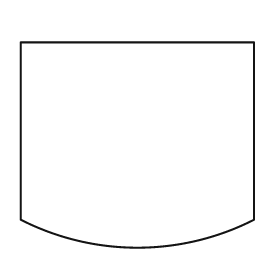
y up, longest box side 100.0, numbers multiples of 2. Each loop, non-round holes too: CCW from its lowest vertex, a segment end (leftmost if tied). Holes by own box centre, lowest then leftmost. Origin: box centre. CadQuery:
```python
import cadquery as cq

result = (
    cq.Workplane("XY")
    .moveTo(-50.0, -32.0)
    .threePointArc((0.0, -44.0), (50.0, -32.0))
    .lineTo(50.0, 44.0)
    .lineTo(-50.0, 44.0)
    .close()
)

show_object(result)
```